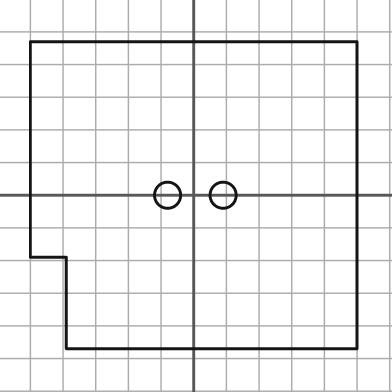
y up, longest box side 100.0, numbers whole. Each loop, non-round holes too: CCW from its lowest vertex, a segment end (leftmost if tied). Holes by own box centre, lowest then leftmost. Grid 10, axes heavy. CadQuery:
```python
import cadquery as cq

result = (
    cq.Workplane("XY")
    .moveTo(-39.0, -47.0)
    .lineTo(50.0, -47.0)
    .lineTo(50.0, 47.0)
    .lineTo(-50.0, 47.0)
    .lineTo(-50.0, -19.0)
    .lineTo(-39.0, -19.0)
    .close()
    .moveTo(-8.0, 0.0)
    .circle(4.0)
    .moveTo(9.0, 0.0)
    .circle(4.0)
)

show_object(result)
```